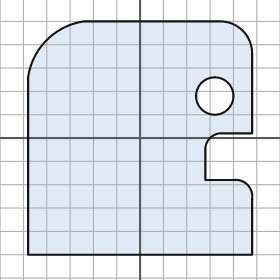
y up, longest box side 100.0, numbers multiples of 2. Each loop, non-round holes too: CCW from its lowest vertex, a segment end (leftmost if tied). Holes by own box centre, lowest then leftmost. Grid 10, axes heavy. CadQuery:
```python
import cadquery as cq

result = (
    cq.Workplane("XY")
    .moveTo(-48.0, -50.0)
    .lineTo(48.0, -50.0)
    .lineTo(48.0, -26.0)
    .threePointArc((46.0, -20.0), (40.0, -18.0))
    .lineTo(28.0, -18.0)
    .lineTo(28.0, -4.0)
    .threePointArc((30.0, 0.0), (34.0, 2.0))
    .lineTo(48.0, 2.0)
    .lineTo(48.0, 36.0)
    .threePointArc((44.0, 46.0), (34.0, 50.0))
    .lineTo(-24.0, 50.0)
    .threePointArc((-40.0, 42.0), (-48.0, 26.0))
    .close()
    .moveTo(32.0, 18.0)
    .circle(8.0)
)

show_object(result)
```